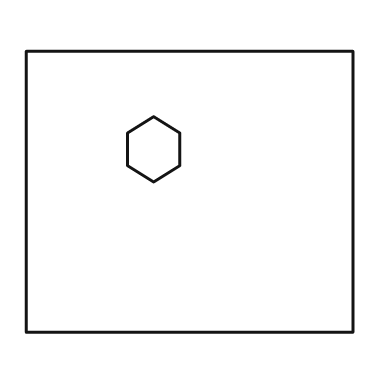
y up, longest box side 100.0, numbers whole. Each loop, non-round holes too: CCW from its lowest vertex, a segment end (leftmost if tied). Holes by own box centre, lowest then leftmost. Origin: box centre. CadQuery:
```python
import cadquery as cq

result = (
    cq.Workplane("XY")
    .moveTo(-50.0, -43.0)
    .lineTo(50.0, -43.0)
    .lineTo(50.0, 43.0)
    .lineTo(-50.0, 43.0)
    .close()
    .moveTo(-11.0, 3.0)
    .lineTo(-3.0, 8.0)
    .lineTo(-3.0, 18.0)
    .lineTo(-11.0, 23.0)
    .lineTo(-19.0, 18.0)
    .lineTo(-19.0, 8.0)
    .close()
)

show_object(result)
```